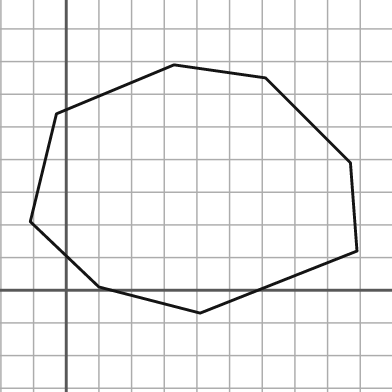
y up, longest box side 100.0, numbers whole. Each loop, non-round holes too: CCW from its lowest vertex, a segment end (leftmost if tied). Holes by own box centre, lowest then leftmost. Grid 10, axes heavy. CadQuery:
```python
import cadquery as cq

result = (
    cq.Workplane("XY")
    .moveTo(41.0, -7.0)
    .lineTo(89.0, 12.0)
    .lineTo(87.0, 39.0)
    .lineTo(61.0, 65.0)
    .lineTo(33.0, 69.0)
    .lineTo(-3.0, 54.0)
    .lineTo(-11.0, 21.0)
    .lineTo(10.0, 1.0)
    .close()
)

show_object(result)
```